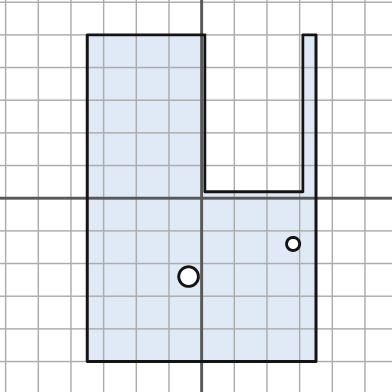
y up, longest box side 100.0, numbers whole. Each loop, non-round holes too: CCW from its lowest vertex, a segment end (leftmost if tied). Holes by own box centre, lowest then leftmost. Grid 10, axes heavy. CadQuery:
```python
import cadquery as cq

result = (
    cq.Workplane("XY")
    .moveTo(-35.0, -50.0)
    .lineTo(35.0, -50.0)
    .lineTo(35.0, 50.0)
    .lineTo(31.0, 50.0)
    .lineTo(31.0, 2.0)
    .lineTo(1.0, 2.0)
    .lineTo(1.0, 50.0)
    .lineTo(-35.0, 50.0)
    .close()
    .moveTo(-4.0, -24.0)
    .circle(3.0)
    .moveTo(28.0, -14.0)
    .circle(2.0)
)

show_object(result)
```